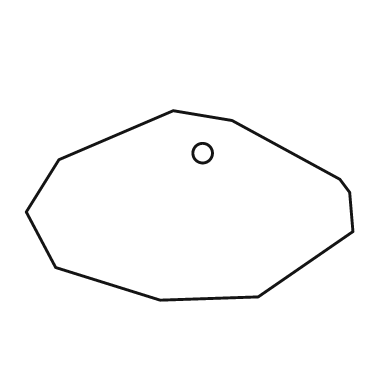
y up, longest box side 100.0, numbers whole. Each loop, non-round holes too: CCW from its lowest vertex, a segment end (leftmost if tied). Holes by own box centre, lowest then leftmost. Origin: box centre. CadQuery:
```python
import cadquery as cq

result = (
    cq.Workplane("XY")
    .moveTo(-9.0, -29.0)
    .lineTo(21.0, -28.0)
    .lineTo(50.0, -8.0)
    .lineTo(49.0, 4.0)
    .lineTo(46.0, 8.0)
    .lineTo(13.0, 26.0)
    .lineTo(-5.0, 29.0)
    .lineTo(-40.0, 14.0)
    .lineTo(-50.0, -2.0)
    .lineTo(-41.0, -19.0)
    .close()
    .moveTo(4.0, 16.0)
    .circle(3.0)
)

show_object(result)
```